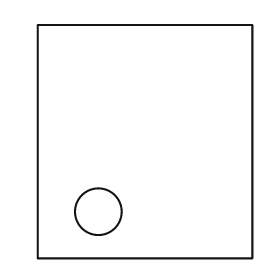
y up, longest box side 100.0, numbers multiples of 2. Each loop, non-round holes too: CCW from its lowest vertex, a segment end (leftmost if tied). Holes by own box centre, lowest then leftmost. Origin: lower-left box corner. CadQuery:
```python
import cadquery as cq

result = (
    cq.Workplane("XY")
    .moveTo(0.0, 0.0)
    .lineTo(92.0, 0.0)
    .lineTo(92.0, 100.0)
    .lineTo(0.0, 100.0)
    .close()
    .moveTo(26.0, 20.0)
    .circle(10.0)
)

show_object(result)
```